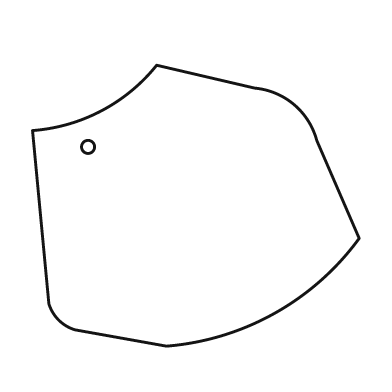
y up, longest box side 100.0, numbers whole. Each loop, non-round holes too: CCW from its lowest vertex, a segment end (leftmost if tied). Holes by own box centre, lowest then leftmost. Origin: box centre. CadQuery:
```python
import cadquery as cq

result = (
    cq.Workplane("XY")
    .moveTo(-9.0, -43.0)
    .threePointArc((24.0, -33.0), (50.0, -10.0))
    .lineTo(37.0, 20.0)
    .threePointArc((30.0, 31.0), (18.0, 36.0))
    .lineTo(-12.0, 43.0)
    .threePointArc((-29.0, 29.0), (-50.0, 23.0))
    .lineTo(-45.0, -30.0)
    .threePointArc((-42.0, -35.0), (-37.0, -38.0))
    .close()
    .moveTo(-33.0, 18.0)
    .circle(2.0)
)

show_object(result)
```